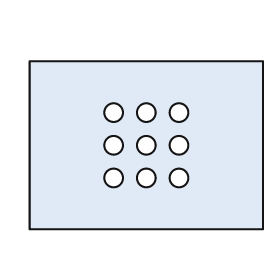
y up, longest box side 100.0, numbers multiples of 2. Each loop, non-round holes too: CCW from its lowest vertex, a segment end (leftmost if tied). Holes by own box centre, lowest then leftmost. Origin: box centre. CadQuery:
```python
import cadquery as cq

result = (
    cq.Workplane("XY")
    .moveTo(-50.0, -36.0)
    .lineTo(50.0, -36.0)
    .lineTo(50.0, 36.0)
    .lineTo(-50.0, 36.0)
    .close()
    .moveTo(-14.0, -14.0)
    .circle(4.0)
    .moveTo(0.0, -14.0)
    .circle(4.0)
    .moveTo(14.0, -14.0)
    .circle(4.0)
    .moveTo(-14.0, 0.0)
    .circle(4.0)
    .moveTo(0.0, 0.0)
    .circle(4.0)
    .moveTo(14.0, 0.0)
    .circle(4.0)
    .moveTo(-14.0, 14.0)
    .circle(4.0)
    .moveTo(0.0, 14.0)
    .circle(4.0)
    .moveTo(14.0, 14.0)
    .circle(4.0)
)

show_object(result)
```